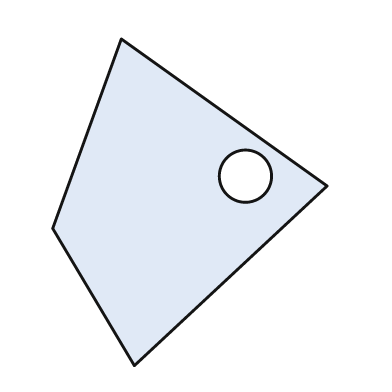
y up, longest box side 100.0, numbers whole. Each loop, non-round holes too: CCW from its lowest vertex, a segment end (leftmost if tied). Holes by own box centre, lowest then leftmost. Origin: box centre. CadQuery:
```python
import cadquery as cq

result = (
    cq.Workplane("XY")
    .moveTo(-17.0, -50.0)
    .lineTo(42.0, 5.0)
    .lineTo(-21.0, 50.0)
    .lineTo(-42.0, -8.0)
    .close()
    .moveTo(17.0, 8.0)
    .circle(8.0)
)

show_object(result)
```